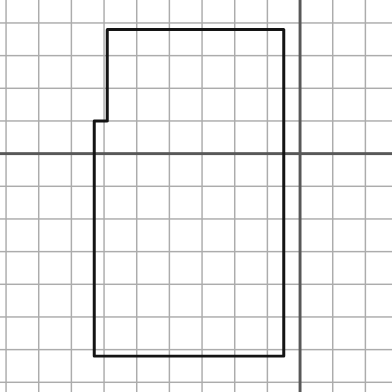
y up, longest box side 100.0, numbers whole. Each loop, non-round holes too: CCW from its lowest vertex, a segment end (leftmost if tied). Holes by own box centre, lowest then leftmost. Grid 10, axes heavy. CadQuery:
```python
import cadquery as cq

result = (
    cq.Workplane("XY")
    .moveTo(-63.0, -62.0)
    .lineTo(-5.0, -62.0)
    .lineTo(-5.0, 38.0)
    .lineTo(-59.0, 38.0)
    .lineTo(-59.0, 10.0)
    .lineTo(-63.0, 10.0)
    .close()
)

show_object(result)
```